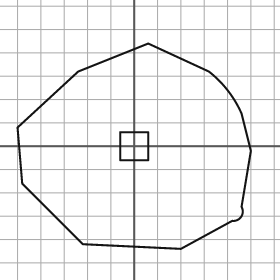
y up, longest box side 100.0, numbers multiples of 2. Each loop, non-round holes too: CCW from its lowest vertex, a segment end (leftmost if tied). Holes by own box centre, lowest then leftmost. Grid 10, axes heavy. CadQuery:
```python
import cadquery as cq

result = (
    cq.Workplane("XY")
    .moveTo(20.0, -44.0)
    .lineTo(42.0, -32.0)
    .threePointArc((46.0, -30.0), (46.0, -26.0))
    .lineTo(50.0, -2.0)
    .lineTo(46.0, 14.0)
    .threePointArc((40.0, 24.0), (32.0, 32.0))
    .lineTo(6.0, 44.0)
    .lineTo(-24.0, 32.0)
    .lineTo(-50.0, 8.0)
    .lineTo(-48.0, -16.0)
    .lineTo(-22.0, -42.0)
    .close()
    .moveTo(-6.0, -6.0)
    .lineTo(6.0, -6.0)
    .lineTo(6.0, 6.0)
    .lineTo(-6.0, 6.0)
    .close()
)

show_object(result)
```